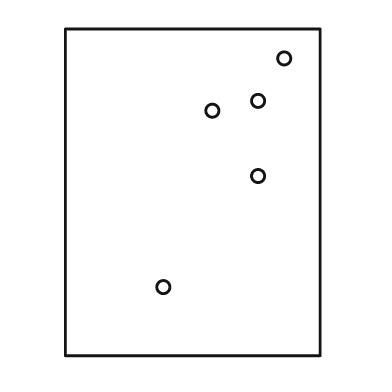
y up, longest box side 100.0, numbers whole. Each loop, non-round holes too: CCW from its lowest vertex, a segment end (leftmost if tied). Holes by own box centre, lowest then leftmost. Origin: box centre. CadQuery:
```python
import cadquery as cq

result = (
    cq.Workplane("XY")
    .moveTo(-39.0, -50.0)
    .lineTo(39.0, -50.0)
    .lineTo(39.0, 50.0)
    .lineTo(-39.0, 50.0)
    .close()
    .moveTo(-9.0, -29.0)
    .circle(2.0)
    .moveTo(20.0, 5.0)
    .circle(2.0)
    .moveTo(6.0, 25.0)
    .circle(2.0)
    .moveTo(20.0, 28.0)
    .circle(2.0)
    .moveTo(28.0, 41.0)
    .circle(2.0)
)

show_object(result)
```